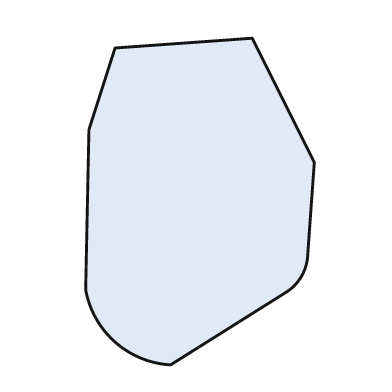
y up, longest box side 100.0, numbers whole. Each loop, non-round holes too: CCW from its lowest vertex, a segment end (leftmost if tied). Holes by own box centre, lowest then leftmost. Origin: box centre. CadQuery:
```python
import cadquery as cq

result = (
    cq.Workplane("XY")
    .moveTo(-9.0, -50.0)
    .lineTo(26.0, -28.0)
    .threePointArc((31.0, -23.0), (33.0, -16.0))
    .lineTo(35.0, 12.0)
    .lineTo(16.0, 50.0)
    .lineTo(-26.0, 47.0)
    .lineTo(-34.0, 22.0)
    .lineTo(-35.0, -27.0)
    .threePointArc((-26.0, -43.0), (-9.0, -50.0))
    .close()
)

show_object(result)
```